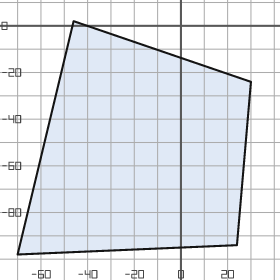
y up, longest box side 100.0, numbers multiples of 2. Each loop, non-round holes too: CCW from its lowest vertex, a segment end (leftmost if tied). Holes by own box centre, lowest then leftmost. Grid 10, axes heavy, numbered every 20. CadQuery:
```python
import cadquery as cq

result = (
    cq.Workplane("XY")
    .moveTo(-70.0, -98.0)
    .lineTo(24.0, -94.0)
    .lineTo(30.0, -24.0)
    .lineTo(-46.0, 2.0)
    .close()
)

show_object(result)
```